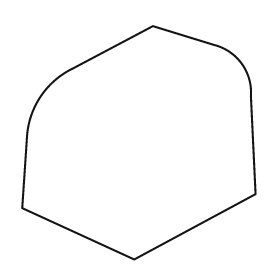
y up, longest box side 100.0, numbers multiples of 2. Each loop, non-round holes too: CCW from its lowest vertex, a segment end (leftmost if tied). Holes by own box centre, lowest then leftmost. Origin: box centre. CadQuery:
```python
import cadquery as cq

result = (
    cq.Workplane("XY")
    .moveTo(-2.0, -50.0)
    .lineTo(50.0, -22.0)
    .lineTo(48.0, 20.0)
    .threePointArc((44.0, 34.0), (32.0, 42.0))
    .lineTo(6.0, 50.0)
    .lineTo(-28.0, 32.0)
    .threePointArc((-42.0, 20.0), (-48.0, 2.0))
    .lineTo(-50.0, -28.0)
    .close()
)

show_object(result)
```